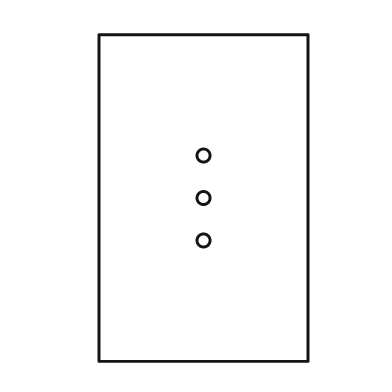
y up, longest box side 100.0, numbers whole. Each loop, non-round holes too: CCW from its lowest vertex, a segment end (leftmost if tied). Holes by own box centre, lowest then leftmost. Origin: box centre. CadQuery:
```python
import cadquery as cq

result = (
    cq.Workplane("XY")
    .moveTo(-32.0, -50.0)
    .lineTo(32.0, -50.0)
    .lineTo(32.0, 50.0)
    .lineTo(-32.0, 50.0)
    .close()
    .moveTo(0.0, -13.0)
    .circle(2.0)
    .moveTo(0.0, 0.0)
    .circle(2.0)
    .moveTo(0.0, 13.0)
    .circle(2.0)
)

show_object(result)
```